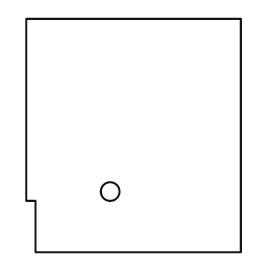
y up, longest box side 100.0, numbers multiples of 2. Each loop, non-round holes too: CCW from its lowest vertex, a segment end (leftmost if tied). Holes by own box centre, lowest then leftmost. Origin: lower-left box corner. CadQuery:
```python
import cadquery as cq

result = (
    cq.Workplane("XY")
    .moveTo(4.0, 0.0)
    .lineTo(92.0, 0.0)
    .lineTo(92.0, 100.0)
    .lineTo(0.0, 100.0)
    .lineTo(0.0, 22.0)
    .lineTo(4.0, 22.0)
    .close()
    .moveTo(36.0, 26.0)
    .circle(4.0)
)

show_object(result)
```